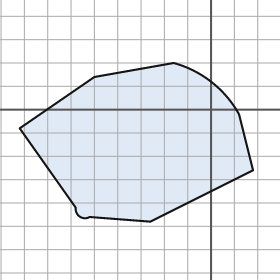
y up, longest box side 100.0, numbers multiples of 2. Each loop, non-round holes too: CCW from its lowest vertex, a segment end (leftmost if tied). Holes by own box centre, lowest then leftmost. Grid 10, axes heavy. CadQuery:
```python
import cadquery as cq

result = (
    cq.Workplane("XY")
    .moveTo(-26.0, -48.0)
    .lineTo(18.0, -26.0)
    .lineTo(12.0, -2.0)
    .threePointArc((0.0, 12.0), (-16.0, 20.0))
    .lineTo(-50.0, 14.0)
    .lineTo(-82.0, -8.0)
    .lineTo(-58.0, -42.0)
    .threePointArc((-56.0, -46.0), (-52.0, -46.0))
    .close()
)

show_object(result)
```